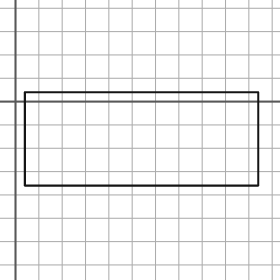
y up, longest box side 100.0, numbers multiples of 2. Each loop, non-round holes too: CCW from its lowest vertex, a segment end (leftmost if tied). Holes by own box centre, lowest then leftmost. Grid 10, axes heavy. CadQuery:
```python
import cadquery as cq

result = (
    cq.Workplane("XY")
    .moveTo(4.0, -36.0)
    .lineTo(104.0, -36.0)
    .lineTo(104.0, 4.0)
    .lineTo(4.0, 4.0)
    .close()
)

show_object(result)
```